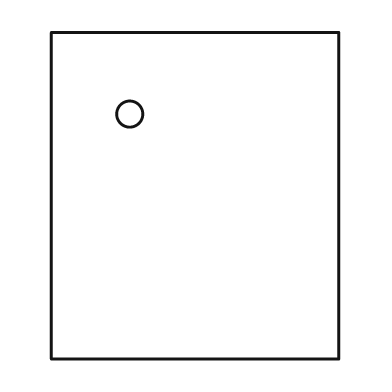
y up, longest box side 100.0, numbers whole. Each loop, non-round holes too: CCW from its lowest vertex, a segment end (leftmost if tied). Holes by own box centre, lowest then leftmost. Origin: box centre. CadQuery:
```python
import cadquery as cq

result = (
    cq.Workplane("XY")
    .moveTo(-44.0, -50.0)
    .lineTo(44.0, -50.0)
    .lineTo(44.0, 50.0)
    .lineTo(-44.0, 50.0)
    .close()
    .moveTo(-20.0, 25.0)
    .circle(4.0)
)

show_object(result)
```